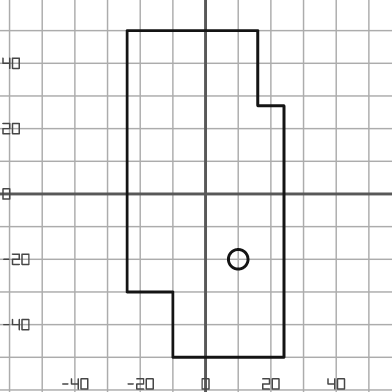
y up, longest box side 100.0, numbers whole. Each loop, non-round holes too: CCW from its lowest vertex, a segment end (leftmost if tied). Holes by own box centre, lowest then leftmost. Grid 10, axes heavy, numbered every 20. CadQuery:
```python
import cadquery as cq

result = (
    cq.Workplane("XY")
    .moveTo(-10.0, -50.0)
    .lineTo(24.0, -50.0)
    .lineTo(24.0, 27.0)
    .lineTo(16.0, 27.0)
    .lineTo(16.0, 50.0)
    .lineTo(-24.0, 50.0)
    .lineTo(-24.0, -30.0)
    .lineTo(-10.0, -30.0)
    .close()
    .moveTo(10.0, -20.0)
    .circle(3.0)
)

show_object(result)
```